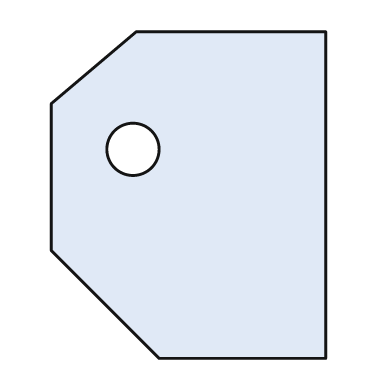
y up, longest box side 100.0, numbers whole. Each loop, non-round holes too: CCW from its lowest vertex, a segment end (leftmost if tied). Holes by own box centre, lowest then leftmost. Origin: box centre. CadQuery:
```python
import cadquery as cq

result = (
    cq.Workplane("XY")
    .moveTo(-9.0, -50.0)
    .lineTo(42.0, -50.0)
    .lineTo(42.0, 50.0)
    .lineTo(-16.0, 50.0)
    .lineTo(-42.0, 28.0)
    .lineTo(-42.0, -17.0)
    .close()
    .moveTo(-17.0, 14.0)
    .circle(8.0)
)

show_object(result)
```